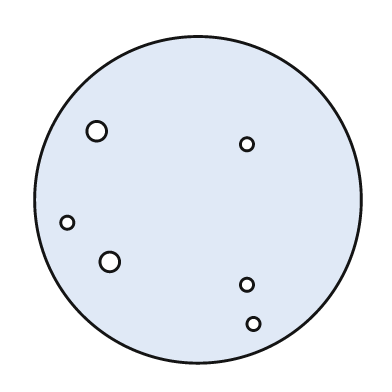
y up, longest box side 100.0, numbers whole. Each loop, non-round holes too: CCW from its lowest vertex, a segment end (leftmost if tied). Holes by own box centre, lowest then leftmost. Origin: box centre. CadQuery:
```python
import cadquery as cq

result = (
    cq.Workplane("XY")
    .moveTo(0.0, 0.0)
    .circle(50.0)
    .moveTo(17.0, -38.0)
    .circle(2.0)
    .moveTo(15.0, -26.0)
    .circle(2.0)
    .moveTo(-27.0, -19.0)
    .circle(3.0)
    .moveTo(-40.0, -7.0)
    .circle(2.0)
    .moveTo(15.0, 17.0)
    .circle(2.0)
    .moveTo(-31.0, 21.0)
    .circle(3.0)
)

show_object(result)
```